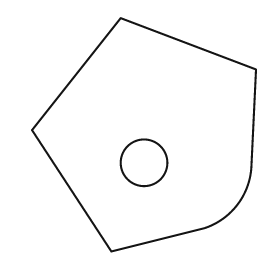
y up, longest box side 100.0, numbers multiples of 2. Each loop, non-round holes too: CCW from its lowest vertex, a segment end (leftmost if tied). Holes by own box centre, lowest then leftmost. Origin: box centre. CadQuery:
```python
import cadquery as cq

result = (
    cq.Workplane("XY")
    .moveTo(-14.0, -50.0)
    .lineTo(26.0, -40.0)
    .threePointArc((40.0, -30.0), (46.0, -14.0))
    .lineTo(48.0, 28.0)
    .lineTo(-10.0, 50.0)
    .lineTo(-48.0, 2.0)
    .close()
    .moveTo(0.0, -12.0)
    .circle(10.0)
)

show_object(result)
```